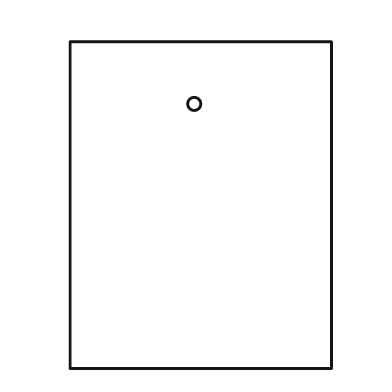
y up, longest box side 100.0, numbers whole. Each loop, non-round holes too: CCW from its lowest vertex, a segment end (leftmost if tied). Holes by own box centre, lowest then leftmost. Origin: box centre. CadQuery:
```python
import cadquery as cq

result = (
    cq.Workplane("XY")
    .moveTo(-40.0, -50.0)
    .lineTo(40.0, -50.0)
    .lineTo(40.0, 50.0)
    .lineTo(-40.0, 50.0)
    .close()
    .moveTo(-2.0, 31.0)
    .circle(2.0)
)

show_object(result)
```